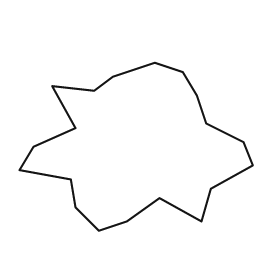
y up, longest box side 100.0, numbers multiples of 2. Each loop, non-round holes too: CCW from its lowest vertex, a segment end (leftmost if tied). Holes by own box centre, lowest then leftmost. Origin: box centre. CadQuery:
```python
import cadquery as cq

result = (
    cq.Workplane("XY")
    .moveTo(-16.0, -36.0)
    .lineTo(-4.0, -32.0)
    .lineTo(10.0, -22.0)
    .lineTo(28.0, -32.0)
    .lineTo(32.0, -18.0)
    .lineTo(50.0, -8.0)
    .lineTo(46.0, 2.0)
    .lineTo(30.0, 10.0)
    .lineTo(26.0, 22.0)
    .lineTo(20.0, 32.0)
    .lineTo(8.0, 36.0)
    .lineTo(-10.0, 30.0)
    .lineTo(-18.0, 24.0)
    .lineTo(-36.0, 26.0)
    .lineTo(-26.0, 8.0)
    .lineTo(-44.0, 0.0)
    .lineTo(-50.0, -10.0)
    .lineTo(-28.0, -14.0)
    .lineTo(-26.0, -26.0)
    .close()
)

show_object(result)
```